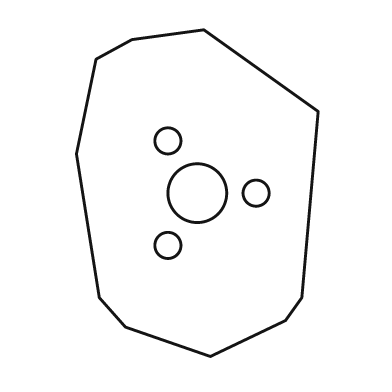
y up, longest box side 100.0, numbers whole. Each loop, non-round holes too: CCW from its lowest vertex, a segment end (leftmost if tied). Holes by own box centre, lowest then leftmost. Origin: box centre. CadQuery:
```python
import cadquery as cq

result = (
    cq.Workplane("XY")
    .moveTo(4.0, -50.0)
    .lineTo(27.0, -39.0)
    .lineTo(32.0, -32.0)
    .lineTo(37.0, 25.0)
    .lineTo(2.0, 50.0)
    .lineTo(-20.0, 47.0)
    .lineTo(-31.0, 41.0)
    .lineTo(-37.0, 12.0)
    .lineTo(-30.0, -32.0)
    .lineTo(-22.0, -41.0)
    .close()
    .moveTo(-9.0, -16.0)
    .circle(4.0)
    .moveTo(0.0, 0.0)
    .circle(9.0)
    .moveTo(18.0, 0.0)
    .circle(4.0)
    .moveTo(-9.0, 16.0)
    .circle(4.0)
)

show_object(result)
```